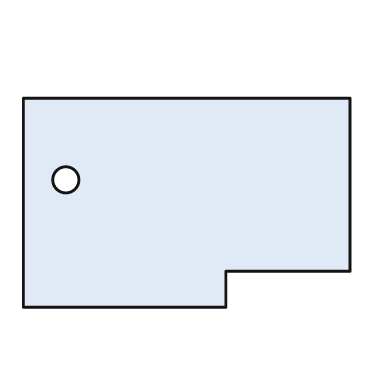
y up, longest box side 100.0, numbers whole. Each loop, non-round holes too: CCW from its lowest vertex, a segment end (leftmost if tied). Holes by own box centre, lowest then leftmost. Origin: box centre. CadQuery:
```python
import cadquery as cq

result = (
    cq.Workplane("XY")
    .moveTo(-50.0, -32.0)
    .lineTo(12.0, -32.0)
    .lineTo(12.0, -21.0)
    .lineTo(50.0, -21.0)
    .lineTo(50.0, 32.0)
    .lineTo(-50.0, 32.0)
    .close()
    .moveTo(-37.0, 7.0)
    .circle(4.0)
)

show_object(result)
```